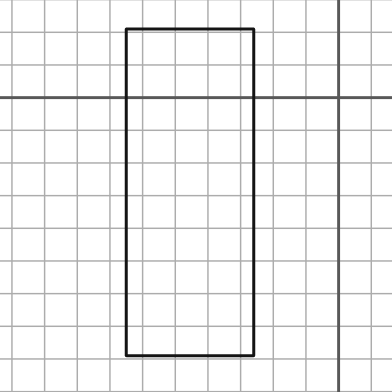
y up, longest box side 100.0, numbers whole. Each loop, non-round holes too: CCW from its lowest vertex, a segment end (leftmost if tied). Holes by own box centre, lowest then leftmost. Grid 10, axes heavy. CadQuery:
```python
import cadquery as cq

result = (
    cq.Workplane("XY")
    .moveTo(-65.0, -79.0)
    .lineTo(-26.0, -79.0)
    .lineTo(-26.0, 21.0)
    .lineTo(-65.0, 21.0)
    .close()
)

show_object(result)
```